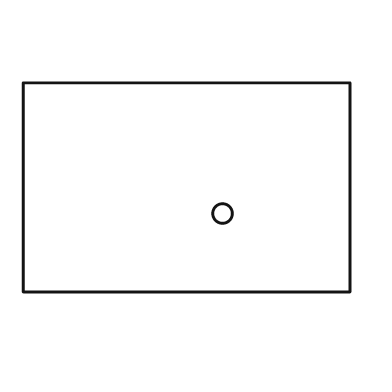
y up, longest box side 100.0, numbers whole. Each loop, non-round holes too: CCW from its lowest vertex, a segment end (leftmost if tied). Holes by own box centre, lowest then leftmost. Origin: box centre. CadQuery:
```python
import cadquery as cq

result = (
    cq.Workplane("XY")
    .moveTo(-50.0, -32.0)
    .lineTo(50.0, -32.0)
    .lineTo(50.0, 32.0)
    .lineTo(-50.0, 32.0)
    .close()
    .moveTo(11.0, -8.0)
    .circle(3.0)
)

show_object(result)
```